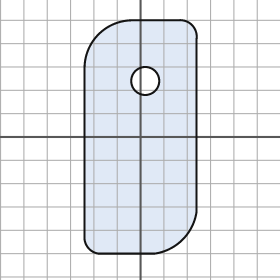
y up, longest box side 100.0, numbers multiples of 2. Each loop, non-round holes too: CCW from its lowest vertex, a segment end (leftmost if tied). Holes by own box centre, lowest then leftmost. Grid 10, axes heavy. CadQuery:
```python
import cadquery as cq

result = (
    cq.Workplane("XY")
    .moveTo(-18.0, -50.0)
    .lineTo(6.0, -50.0)
    .threePointArc((18.0, -44.0), (24.0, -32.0))
    .lineTo(24.0, 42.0)
    .threePointArc((22.0, 48.0), (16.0, 50.0))
    .lineTo(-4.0, 50.0)
    .threePointArc((-18.0, 44.0), (-24.0, 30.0))
    .lineTo(-24.0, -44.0)
    .threePointArc((-22.0, -48.0), (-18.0, -50.0))
    .close()
    .moveTo(2.0, 24.0)
    .circle(6.0)
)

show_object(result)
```